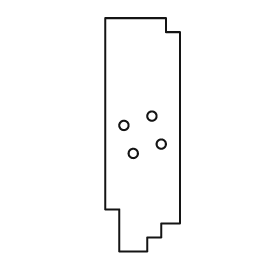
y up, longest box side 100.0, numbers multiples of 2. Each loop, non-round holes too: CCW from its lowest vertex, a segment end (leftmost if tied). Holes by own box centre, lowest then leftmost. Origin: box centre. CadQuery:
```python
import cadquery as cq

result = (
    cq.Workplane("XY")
    .moveTo(-10.0, -50.0)
    .lineTo(2.0, -50.0)
    .lineTo(2.0, -44.0)
    .lineTo(8.0, -44.0)
    .lineTo(8.0, -38.0)
    .lineTo(16.0, -38.0)
    .lineTo(16.0, 44.0)
    .lineTo(10.0, 44.0)
    .lineTo(10.0, 50.0)
    .lineTo(-16.0, 50.0)
    .lineTo(-16.0, -32.0)
    .lineTo(-10.0, -32.0)
    .close()
    .moveTo(-4.0, -8.0)
    .circle(2.0)
    .moveTo(8.0, -4.0)
    .circle(2.0)
    .moveTo(-8.0, 4.0)
    .circle(2.0)
    .moveTo(4.0, 8.0)
    .circle(2.0)
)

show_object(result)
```